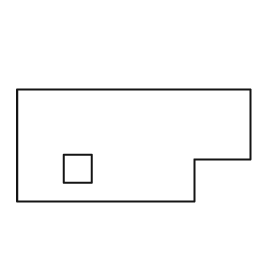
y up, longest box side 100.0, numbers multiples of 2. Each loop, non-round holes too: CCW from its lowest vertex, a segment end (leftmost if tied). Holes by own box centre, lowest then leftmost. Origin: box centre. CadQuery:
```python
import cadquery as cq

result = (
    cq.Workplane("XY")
    .moveTo(-50.0, -24.0)
    .lineTo(26.0, -24.0)
    .lineTo(26.0, -6.0)
    .lineTo(50.0, -6.0)
    .lineTo(50.0, 24.0)
    .lineTo(-50.0, 24.0)
    .close()
    .moveTo(-30.0, -16.0)
    .lineTo(-18.0, -16.0)
    .lineTo(-18.0, -4.0)
    .lineTo(-30.0, -4.0)
    .close()
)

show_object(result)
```